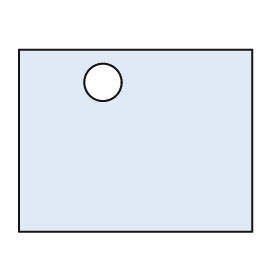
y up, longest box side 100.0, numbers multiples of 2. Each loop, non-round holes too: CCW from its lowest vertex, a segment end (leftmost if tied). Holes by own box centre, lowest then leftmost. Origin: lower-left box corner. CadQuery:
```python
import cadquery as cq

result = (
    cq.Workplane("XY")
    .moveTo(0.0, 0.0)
    .lineTo(100.0, 0.0)
    .lineTo(100.0, 78.0)
    .lineTo(0.0, 78.0)
    .close()
    .moveTo(36.0, 64.0)
    .circle(8.0)
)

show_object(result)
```